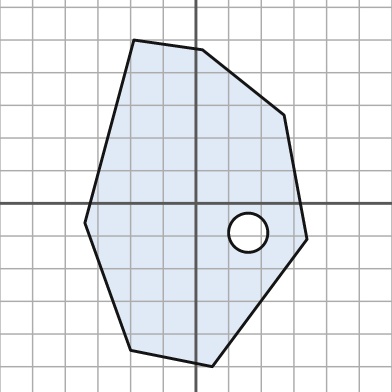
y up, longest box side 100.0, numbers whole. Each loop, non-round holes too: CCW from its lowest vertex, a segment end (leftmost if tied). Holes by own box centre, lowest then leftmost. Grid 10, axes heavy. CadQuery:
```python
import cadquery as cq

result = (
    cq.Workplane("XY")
    .moveTo(5.0, -50.0)
    .lineTo(34.0, -11.0)
    .lineTo(27.0, 27.0)
    .lineTo(2.0, 47.0)
    .lineTo(-19.0, 50.0)
    .lineTo(-34.0, -6.0)
    .lineTo(-20.0, -45.0)
    .close()
    .moveTo(16.0, -9.0)
    .circle(6.0)
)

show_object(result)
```